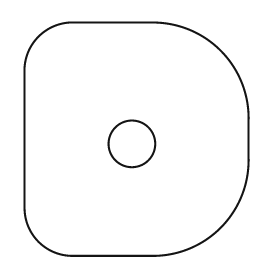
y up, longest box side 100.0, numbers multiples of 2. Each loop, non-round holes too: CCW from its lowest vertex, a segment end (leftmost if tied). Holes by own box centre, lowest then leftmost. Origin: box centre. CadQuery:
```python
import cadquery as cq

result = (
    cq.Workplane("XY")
    .moveTo(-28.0, -50.0)
    .lineTo(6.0, -50.0)
    .threePointArc((36.0, -38.0), (48.0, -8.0))
    .lineTo(48.0, 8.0)
    .threePointArc((36.0, 38.0), (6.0, 50.0))
    .lineTo(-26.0, 50.0)
    .threePointArc((-42.0, 44.0), (-48.0, 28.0))
    .lineTo(-48.0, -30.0)
    .threePointArc((-42.0, -44.0), (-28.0, -50.0))
    .close()
    .moveTo(-2.0, -2.0)
    .circle(10.0)
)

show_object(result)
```